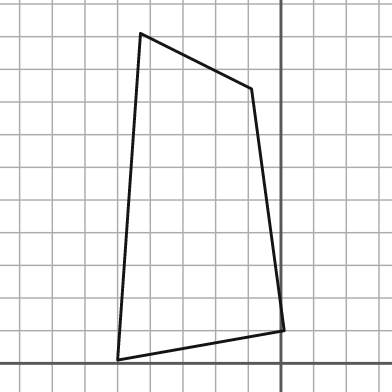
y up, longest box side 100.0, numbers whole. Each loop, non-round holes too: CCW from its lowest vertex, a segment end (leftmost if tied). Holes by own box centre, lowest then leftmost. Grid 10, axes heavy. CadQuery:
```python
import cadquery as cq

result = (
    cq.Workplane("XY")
    .moveTo(-50.0, 1.0)
    .lineTo(1.0, 10.0)
    .lineTo(-9.0, 84.0)
    .lineTo(-43.0, 101.0)
    .close()
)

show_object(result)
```